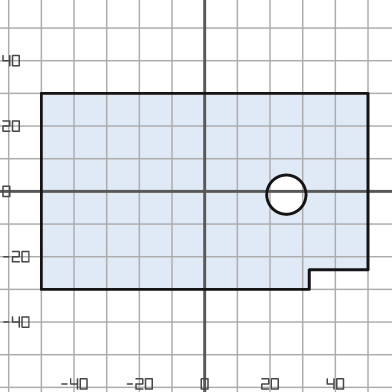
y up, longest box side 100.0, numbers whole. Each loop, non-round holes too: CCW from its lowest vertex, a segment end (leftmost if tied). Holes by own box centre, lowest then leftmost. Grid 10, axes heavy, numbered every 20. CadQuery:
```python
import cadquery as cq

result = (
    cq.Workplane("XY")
    .moveTo(-50.0, -30.0)
    .lineTo(32.0, -30.0)
    .lineTo(32.0, -24.0)
    .lineTo(50.0, -24.0)
    .lineTo(50.0, 30.0)
    .lineTo(-50.0, 30.0)
    .close()
    .moveTo(25.0, -1.0)
    .circle(6.0)
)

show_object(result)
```